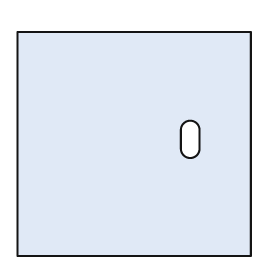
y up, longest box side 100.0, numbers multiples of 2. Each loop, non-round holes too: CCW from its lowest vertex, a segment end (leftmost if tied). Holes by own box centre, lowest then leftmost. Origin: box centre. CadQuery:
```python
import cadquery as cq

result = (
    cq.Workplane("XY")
    .moveTo(-50.0, -48.0)
    .lineTo(50.0, -48.0)
    .lineTo(50.0, 48.0)
    .lineTo(-50.0, 48.0)
    .close()
    .moveTo(20.0, -2.0)
    .threePointArc((24.0, -6.0), (28.0, -2.0))
    .lineTo(28.0, 6.0)
    .threePointArc((24.0, 10.0), (20.0, 6.0))
    .close()
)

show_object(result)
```